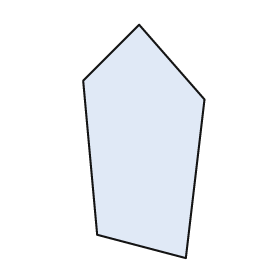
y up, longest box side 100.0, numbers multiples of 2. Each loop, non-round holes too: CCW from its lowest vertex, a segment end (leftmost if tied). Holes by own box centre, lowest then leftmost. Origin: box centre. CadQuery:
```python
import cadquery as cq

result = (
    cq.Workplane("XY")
    .moveTo(18.0, -50.0)
    .lineTo(26.0, 18.0)
    .lineTo(-2.0, 50.0)
    .lineTo(-26.0, 26.0)
    .lineTo(-20.0, -40.0)
    .close()
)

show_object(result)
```